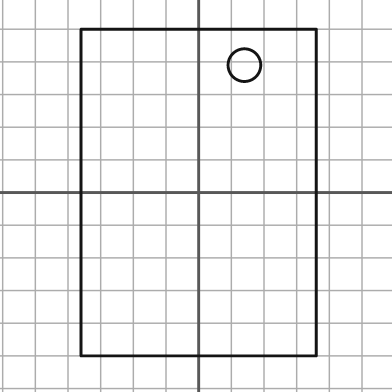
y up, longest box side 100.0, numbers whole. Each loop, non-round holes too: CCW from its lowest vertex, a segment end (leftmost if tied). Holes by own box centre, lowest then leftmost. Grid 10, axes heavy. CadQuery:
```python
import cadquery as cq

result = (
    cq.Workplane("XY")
    .moveTo(-36.0, -50.0)
    .lineTo(36.0, -50.0)
    .lineTo(36.0, 50.0)
    .lineTo(-36.0, 50.0)
    .close()
    .moveTo(14.0, 39.0)
    .circle(5.0)
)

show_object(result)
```